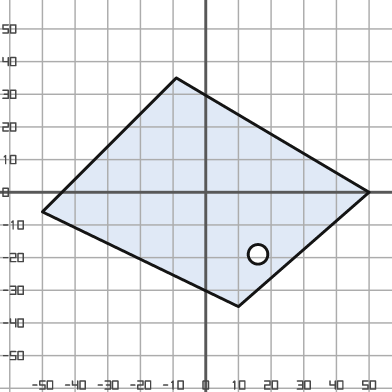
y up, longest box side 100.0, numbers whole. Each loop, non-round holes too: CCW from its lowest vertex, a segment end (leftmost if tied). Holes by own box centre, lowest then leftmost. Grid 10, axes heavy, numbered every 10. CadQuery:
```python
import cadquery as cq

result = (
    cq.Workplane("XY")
    .moveTo(10.0, -35.0)
    .lineTo(50.0, 0.0)
    .lineTo(-9.0, 35.0)
    .lineTo(-50.0, -6.0)
    .close()
    .moveTo(16.0, -19.0)
    .circle(3.0)
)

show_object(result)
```